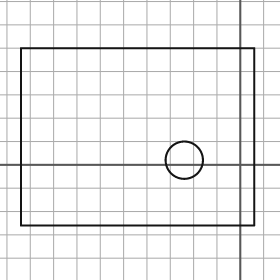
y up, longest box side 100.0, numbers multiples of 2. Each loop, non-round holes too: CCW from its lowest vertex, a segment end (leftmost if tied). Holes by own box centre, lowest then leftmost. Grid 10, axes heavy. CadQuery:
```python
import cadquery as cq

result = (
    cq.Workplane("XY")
    .moveTo(-94.0, -26.0)
    .lineTo(6.0, -26.0)
    .lineTo(6.0, 50.0)
    .lineTo(-94.0, 50.0)
    .close()
    .moveTo(-24.0, 2.0)
    .circle(8.0)
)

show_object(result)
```